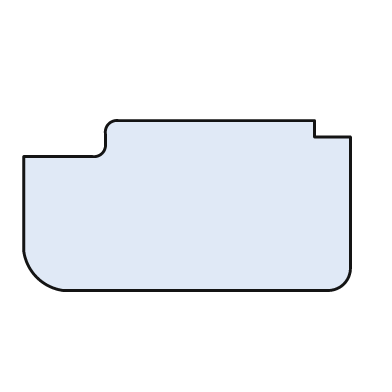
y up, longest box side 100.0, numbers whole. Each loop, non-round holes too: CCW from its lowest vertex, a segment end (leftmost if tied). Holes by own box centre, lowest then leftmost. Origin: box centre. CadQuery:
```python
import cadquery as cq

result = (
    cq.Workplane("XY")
    .moveTo(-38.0, -26.0)
    .lineTo(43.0, -26.0)
    .threePointArc((48.0, -24.0), (50.0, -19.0))
    .lineTo(50.0, 21.0)
    .lineTo(39.0, 21.0)
    .lineTo(39.0, 26.0)
    .lineTo(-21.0, 26.0)
    .threePointArc((-24.0, 25.0), (-25.0, 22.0))
    .lineTo(-25.0, 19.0)
    .threePointArc((-26.0, 16.0), (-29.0, 15.0))
    .lineTo(-50.0, 15.0)
    .lineTo(-50.0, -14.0)
    .threePointArc((-46.0, -22.0), (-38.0, -26.0))
    .close()
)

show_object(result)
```